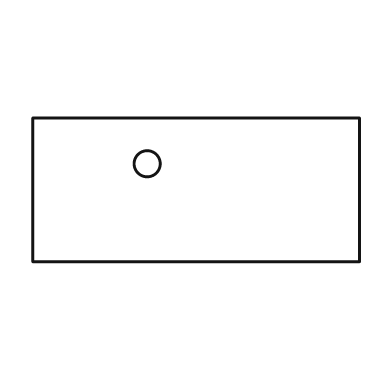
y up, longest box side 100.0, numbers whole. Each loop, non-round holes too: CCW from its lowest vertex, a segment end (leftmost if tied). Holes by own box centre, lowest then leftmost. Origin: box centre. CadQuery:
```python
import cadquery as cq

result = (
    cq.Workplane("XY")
    .moveTo(-50.0, -22.0)
    .lineTo(50.0, -22.0)
    .lineTo(50.0, 22.0)
    .lineTo(-50.0, 22.0)
    .close()
    .moveTo(-15.0, 8.0)
    .circle(4.0)
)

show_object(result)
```